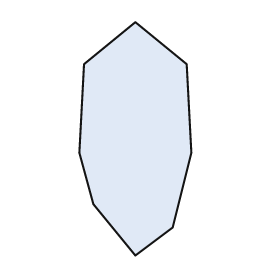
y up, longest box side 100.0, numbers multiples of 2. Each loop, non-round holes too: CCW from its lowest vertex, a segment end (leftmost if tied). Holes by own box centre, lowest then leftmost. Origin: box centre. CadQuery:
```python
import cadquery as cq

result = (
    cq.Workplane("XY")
    .moveTo(0.0, -50.0)
    .lineTo(16.0, -38.0)
    .lineTo(24.0, -6.0)
    .lineTo(22.0, 32.0)
    .lineTo(0.0, 50.0)
    .lineTo(-22.0, 32.0)
    .lineTo(-24.0, -6.0)
    .lineTo(-18.0, -28.0)
    .close()
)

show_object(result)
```